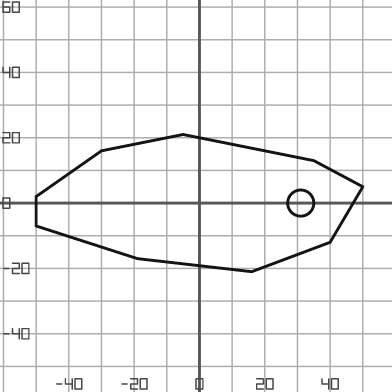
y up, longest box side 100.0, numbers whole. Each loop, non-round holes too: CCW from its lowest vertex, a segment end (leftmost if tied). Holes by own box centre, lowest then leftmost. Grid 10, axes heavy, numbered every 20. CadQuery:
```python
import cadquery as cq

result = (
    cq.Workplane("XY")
    .moveTo(16.0, -21.0)
    .lineTo(40.0, -12.0)
    .lineTo(50.0, 5.0)
    .lineTo(35.0, 13.0)
    .lineTo(-5.0, 21.0)
    .lineTo(-30.0, 16.0)
    .lineTo(-50.0, 2.0)
    .lineTo(-50.0, -7.0)
    .lineTo(-19.0, -17.0)
    .close()
    .moveTo(31.0, 0.0)
    .circle(4.0)
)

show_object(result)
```